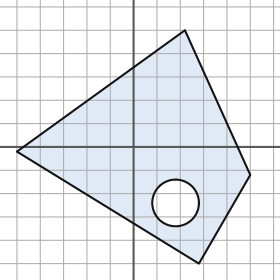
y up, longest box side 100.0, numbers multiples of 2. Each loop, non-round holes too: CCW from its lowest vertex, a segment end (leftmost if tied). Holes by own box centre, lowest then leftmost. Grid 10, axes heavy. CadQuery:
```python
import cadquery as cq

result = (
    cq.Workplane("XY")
    .moveTo(28.0, -50.0)
    .lineTo(50.0, -12.0)
    .lineTo(22.0, 50.0)
    .lineTo(-50.0, -2.0)
    .close()
    .moveTo(18.0, -24.0)
    .circle(10.0)
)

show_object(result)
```